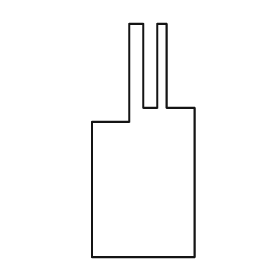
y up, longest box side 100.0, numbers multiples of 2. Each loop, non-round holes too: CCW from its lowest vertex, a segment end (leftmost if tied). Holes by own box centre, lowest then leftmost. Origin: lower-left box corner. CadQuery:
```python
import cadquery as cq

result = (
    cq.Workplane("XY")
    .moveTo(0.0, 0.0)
    .lineTo(44.0, 0.0)
    .lineTo(44.0, 64.0)
    .lineTo(32.0, 64.0)
    .lineTo(32.0, 100.0)
    .lineTo(28.0, 100.0)
    .lineTo(28.0, 64.0)
    .lineTo(22.0, 64.0)
    .lineTo(22.0, 100.0)
    .lineTo(16.0, 100.0)
    .lineTo(16.0, 58.0)
    .lineTo(0.0, 58.0)
    .close()
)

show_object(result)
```